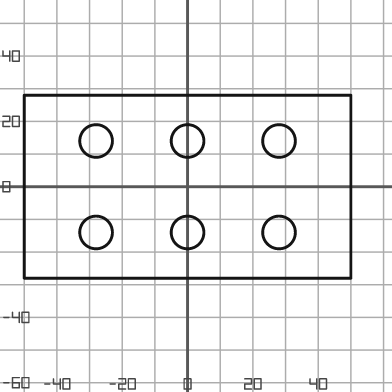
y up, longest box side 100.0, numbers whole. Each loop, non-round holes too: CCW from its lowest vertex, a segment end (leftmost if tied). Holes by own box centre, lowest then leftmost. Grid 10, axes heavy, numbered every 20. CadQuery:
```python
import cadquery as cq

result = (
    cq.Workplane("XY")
    .moveTo(-50.0, -28.0)
    .lineTo(50.0, -28.0)
    .lineTo(50.0, 28.0)
    .lineTo(-50.0, 28.0)
    .close()
    .moveTo(-28.0, -14.0)
    .circle(5.0)
    .moveTo(0.0, -14.0)
    .circle(5.0)
    .moveTo(28.0, -14.0)
    .circle(5.0)
    .moveTo(-28.0, 14.0)
    .circle(5.0)
    .moveTo(0.0, 14.0)
    .circle(5.0)
    .moveTo(28.0, 14.0)
    .circle(5.0)
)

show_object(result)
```